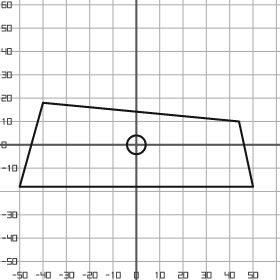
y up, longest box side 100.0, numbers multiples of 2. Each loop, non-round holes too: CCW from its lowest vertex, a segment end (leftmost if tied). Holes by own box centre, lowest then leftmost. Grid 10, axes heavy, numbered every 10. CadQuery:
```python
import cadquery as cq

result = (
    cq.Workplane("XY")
    .moveTo(-50.0, -18.0)
    .lineTo(50.0, -18.0)
    .lineTo(44.0, 10.0)
    .lineTo(-40.0, 18.0)
    .close()
    .moveTo(0.0, 0.0)
    .circle(4.0)
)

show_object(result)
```